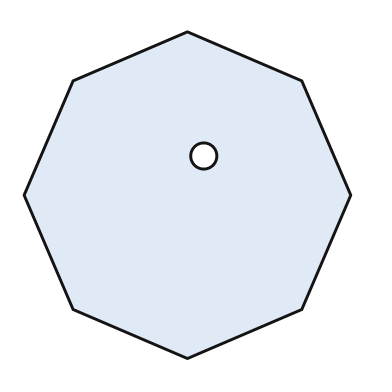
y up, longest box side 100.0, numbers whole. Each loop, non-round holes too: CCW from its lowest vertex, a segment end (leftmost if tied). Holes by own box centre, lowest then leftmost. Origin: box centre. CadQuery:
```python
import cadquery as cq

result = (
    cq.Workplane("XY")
    .moveTo(0.0, -50.0)
    .lineTo(35.0, -35.0)
    .lineTo(50.0, 0.0)
    .lineTo(35.0, 35.0)
    .lineTo(0.0, 50.0)
    .lineTo(-35.0, 35.0)
    .lineTo(-50.0, 0.0)
    .lineTo(-35.0, -35.0)
    .close()
    .moveTo(5.0, 12.0)
    .circle(4.0)
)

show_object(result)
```